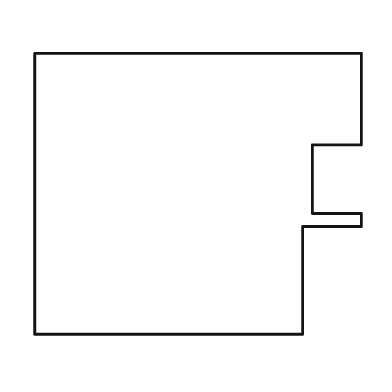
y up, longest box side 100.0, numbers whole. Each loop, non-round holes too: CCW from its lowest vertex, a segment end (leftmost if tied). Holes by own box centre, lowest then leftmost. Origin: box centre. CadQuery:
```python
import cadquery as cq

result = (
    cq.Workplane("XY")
    .moveTo(-50.0, -43.0)
    .lineTo(32.0, -43.0)
    .lineTo(32.0, -10.0)
    .lineTo(50.0, -10.0)
    .lineTo(50.0, -6.0)
    .lineTo(35.0, -6.0)
    .lineTo(35.0, 15.0)
    .lineTo(50.0, 15.0)
    .lineTo(50.0, 43.0)
    .lineTo(-50.0, 43.0)
    .close()
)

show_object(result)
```